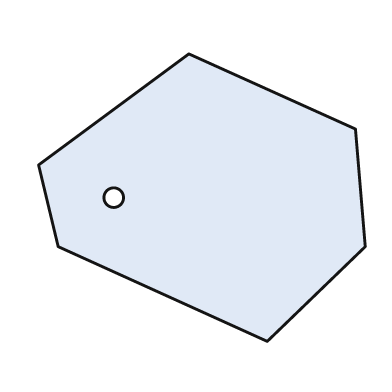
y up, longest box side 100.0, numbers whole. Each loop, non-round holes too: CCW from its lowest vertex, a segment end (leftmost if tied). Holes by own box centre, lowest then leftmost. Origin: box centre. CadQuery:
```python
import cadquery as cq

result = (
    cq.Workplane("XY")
    .moveTo(20.0, -44.0)
    .lineTo(50.0, -15.0)
    .lineTo(47.0, 21.0)
    .lineTo(-4.0, 44.0)
    .lineTo(-50.0, 10.0)
    .lineTo(-44.0, -15.0)
    .close()
    .moveTo(-27.0, 0.0)
    .circle(3.0)
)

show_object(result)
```